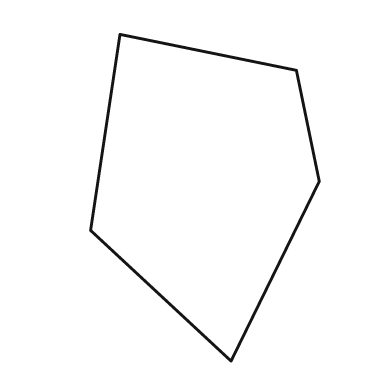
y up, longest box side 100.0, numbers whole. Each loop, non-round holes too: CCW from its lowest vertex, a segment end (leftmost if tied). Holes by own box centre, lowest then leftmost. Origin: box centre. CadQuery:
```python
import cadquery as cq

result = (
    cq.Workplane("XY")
    .moveTo(8.0, -50.0)
    .lineTo(35.0, 5.0)
    .lineTo(28.0, 39.0)
    .lineTo(-26.0, 50.0)
    .lineTo(-35.0, -10.0)
    .close()
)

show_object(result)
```